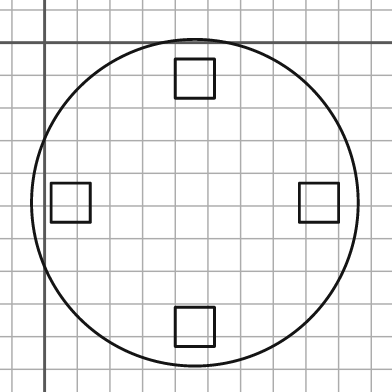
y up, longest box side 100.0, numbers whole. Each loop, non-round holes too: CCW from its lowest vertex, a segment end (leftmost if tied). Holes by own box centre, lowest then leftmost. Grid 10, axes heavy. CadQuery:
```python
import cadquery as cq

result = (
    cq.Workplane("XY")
    .moveTo(46.0, -49.0)
    .circle(50.0)
    .moveTo(40.0, -93.0)
    .lineTo(52.0, -93.0)
    .lineTo(52.0, -81.0)
    .lineTo(40.0, -81.0)
    .close()
    .moveTo(2.0, -55.0)
    .lineTo(14.0, -55.0)
    .lineTo(14.0, -43.0)
    .lineTo(2.0, -43.0)
    .close()
    .moveTo(78.0, -55.0)
    .lineTo(90.0, -55.0)
    .lineTo(90.0, -43.0)
    .lineTo(78.0, -43.0)
    .close()
    .moveTo(40.0, -17.0)
    .lineTo(52.0, -17.0)
    .lineTo(52.0, -5.0)
    .lineTo(40.0, -5.0)
    .close()
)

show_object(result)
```